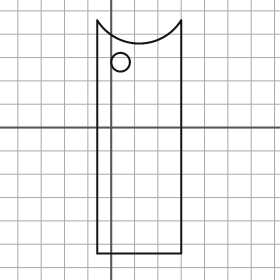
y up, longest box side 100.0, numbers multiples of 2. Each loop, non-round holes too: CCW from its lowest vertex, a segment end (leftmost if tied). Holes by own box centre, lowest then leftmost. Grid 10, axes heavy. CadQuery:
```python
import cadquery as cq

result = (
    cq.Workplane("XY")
    .moveTo(-6.0, -54.0)
    .lineTo(30.0, -54.0)
    .lineTo(30.0, 46.0)
    .threePointArc((12.0, 36.0), (-6.0, 46.0))
    .close()
    .moveTo(4.0, 28.0)
    .circle(4.0)
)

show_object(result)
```